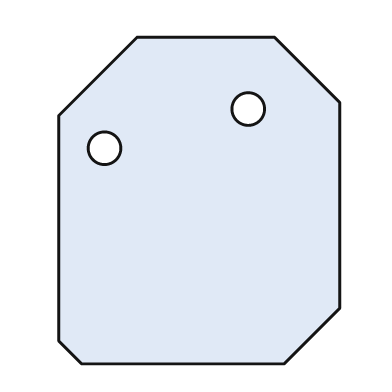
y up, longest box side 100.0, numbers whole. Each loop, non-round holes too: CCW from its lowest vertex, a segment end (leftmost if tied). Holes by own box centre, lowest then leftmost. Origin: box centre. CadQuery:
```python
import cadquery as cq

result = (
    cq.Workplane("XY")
    .moveTo(-36.0, -50.0)
    .lineTo(26.0, -50.0)
    .lineTo(43.0, -33.0)
    .lineTo(43.0, 30.0)
    .lineTo(23.0, 50.0)
    .lineTo(-19.0, 50.0)
    .lineTo(-43.0, 26.0)
    .lineTo(-43.0, -43.0)
    .close()
    .moveTo(-29.0, 16.0)
    .circle(5.0)
    .moveTo(15.0, 28.0)
    .circle(5.0)
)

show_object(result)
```